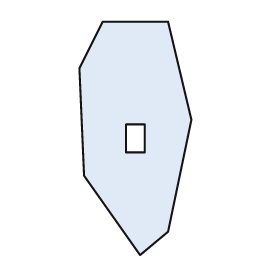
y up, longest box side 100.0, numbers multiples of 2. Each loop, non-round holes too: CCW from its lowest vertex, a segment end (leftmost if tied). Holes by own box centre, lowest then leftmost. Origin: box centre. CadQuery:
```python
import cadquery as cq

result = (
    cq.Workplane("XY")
    .moveTo(2.0, -50.0)
    .lineTo(14.0, -40.0)
    .lineTo(24.0, 8.0)
    .lineTo(14.0, 50.0)
    .lineTo(-14.0, 50.0)
    .lineTo(-24.0, 30.0)
    .lineTo(-22.0, -16.0)
    .close()
    .moveTo(-4.0, -6.0)
    .lineTo(4.0, -6.0)
    .lineTo(4.0, 6.0)
    .lineTo(-4.0, 6.0)
    .close()
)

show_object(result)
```